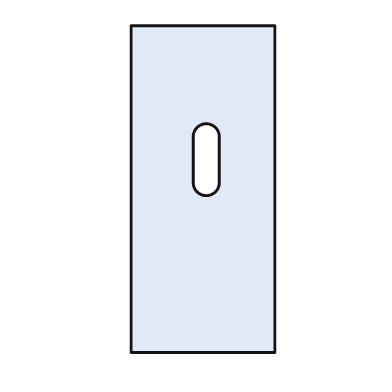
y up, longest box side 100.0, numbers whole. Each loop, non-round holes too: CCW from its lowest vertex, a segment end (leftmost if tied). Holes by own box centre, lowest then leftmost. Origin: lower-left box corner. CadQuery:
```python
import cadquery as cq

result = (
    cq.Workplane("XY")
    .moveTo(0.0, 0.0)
    .lineTo(44.0, 0.0)
    .lineTo(44.0, 100.0)
    .lineTo(0.0, 100.0)
    .close()
    .moveTo(19.0, 52.0)
    .threePointArc((23.0, 48.0), (27.0, 52.0))
    .lineTo(27.0, 66.0)
    .threePointArc((23.0, 70.0), (19.0, 66.0))
    .close()
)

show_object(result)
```